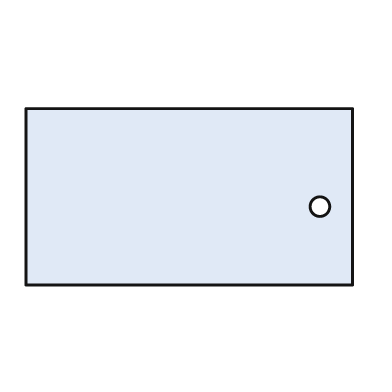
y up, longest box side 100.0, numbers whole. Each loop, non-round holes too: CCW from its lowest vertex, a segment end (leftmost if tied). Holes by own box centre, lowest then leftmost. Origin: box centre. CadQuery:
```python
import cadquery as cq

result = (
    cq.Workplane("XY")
    .moveTo(-50.0, -27.0)
    .lineTo(50.0, -27.0)
    .lineTo(50.0, 27.0)
    .lineTo(-50.0, 27.0)
    .close()
    .moveTo(40.0, -3.0)
    .circle(3.0)
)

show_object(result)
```